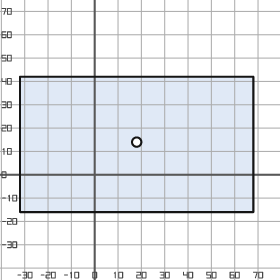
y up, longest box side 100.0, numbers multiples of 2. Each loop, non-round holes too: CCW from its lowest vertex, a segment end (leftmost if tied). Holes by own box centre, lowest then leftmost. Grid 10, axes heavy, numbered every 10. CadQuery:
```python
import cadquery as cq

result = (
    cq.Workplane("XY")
    .moveTo(-32.0, -16.0)
    .lineTo(68.0, -16.0)
    .lineTo(68.0, 42.0)
    .lineTo(-32.0, 42.0)
    .close()
    .moveTo(18.0, 14.0)
    .circle(2.0)
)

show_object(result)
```